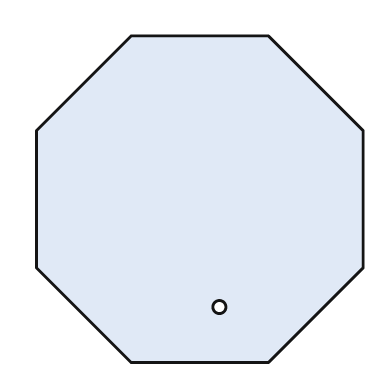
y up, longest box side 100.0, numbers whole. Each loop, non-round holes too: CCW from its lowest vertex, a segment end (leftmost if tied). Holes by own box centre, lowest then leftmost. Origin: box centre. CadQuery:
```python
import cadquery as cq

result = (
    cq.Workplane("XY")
    .moveTo(-21.0, -50.0)
    .lineTo(21.0, -50.0)
    .lineTo(50.0, -21.0)
    .lineTo(50.0, 21.0)
    .lineTo(21.0, 50.0)
    .lineTo(-21.0, 50.0)
    .lineTo(-50.0, 21.0)
    .lineTo(-50.0, -21.0)
    .close()
    .moveTo(6.0, -33.0)
    .circle(2.0)
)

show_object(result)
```